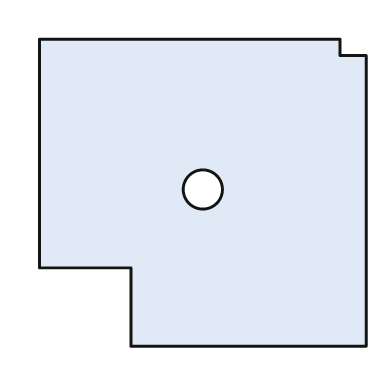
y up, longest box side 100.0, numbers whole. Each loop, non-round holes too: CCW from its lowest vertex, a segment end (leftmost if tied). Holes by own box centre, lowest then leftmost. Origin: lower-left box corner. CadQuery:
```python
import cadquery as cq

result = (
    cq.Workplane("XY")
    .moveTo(28.0, 0.0)
    .lineTo(100.0, 0.0)
    .lineTo(100.0, 89.0)
    .lineTo(92.0, 89.0)
    .lineTo(92.0, 94.0)
    .lineTo(0.0, 94.0)
    .lineTo(0.0, 24.0)
    .lineTo(28.0, 24.0)
    .close()
    .moveTo(50.0, 48.0)
    .circle(6.0)
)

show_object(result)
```